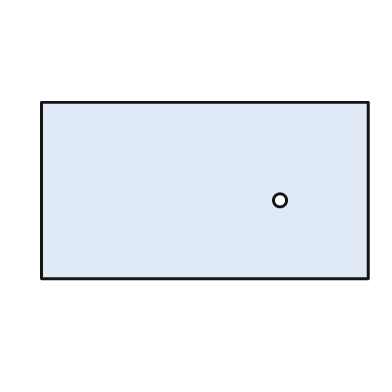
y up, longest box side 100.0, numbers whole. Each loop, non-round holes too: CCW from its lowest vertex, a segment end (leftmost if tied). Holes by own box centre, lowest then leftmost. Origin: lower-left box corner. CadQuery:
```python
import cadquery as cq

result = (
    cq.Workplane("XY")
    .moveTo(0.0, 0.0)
    .lineTo(100.0, 0.0)
    .lineTo(100.0, 54.0)
    .lineTo(0.0, 54.0)
    .close()
    .moveTo(73.0, 24.0)
    .circle(2.0)
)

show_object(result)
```